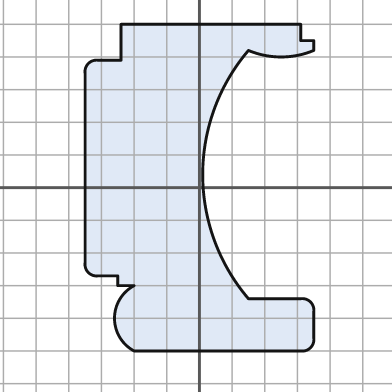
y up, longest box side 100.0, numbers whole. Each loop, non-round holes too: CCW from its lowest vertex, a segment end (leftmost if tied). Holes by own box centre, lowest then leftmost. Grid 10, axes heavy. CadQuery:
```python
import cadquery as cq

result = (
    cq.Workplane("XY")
    .moveTo(-20.0, -50.0)
    .lineTo(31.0, -50.0)
    .threePointArc((34.0, -49.0), (35.0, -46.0))
    .lineTo(35.0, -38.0)
    .threePointArc((34.0, -35.0), (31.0, -34.0))
    .lineTo(15.0, -34.0)
    .threePointArc((1.0, 4.0), (15.0, 42.0))
    .threePointArc((25.0, 40.0), (35.0, 42.0))
    .lineTo(35.0, 45.0)
    .lineTo(31.0, 45.0)
    .lineTo(31.0, 50.0)
    .lineTo(-24.0, 50.0)
    .lineTo(-24.0, 39.0)
    .lineTo(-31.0, 39.0)
    .threePointArc((-34.0, 38.0), (-35.0, 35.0))
    .lineTo(-35.0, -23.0)
    .threePointArc((-34.0, -26.0), (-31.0, -27.0))
    .lineTo(-25.0, -27.0)
    .lineTo(-25.0, -30.0)
    .lineTo(-20.0, -30.0)
    .threePointArc((-26.0, -40.0), (-20.0, -50.0))
    .close()
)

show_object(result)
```